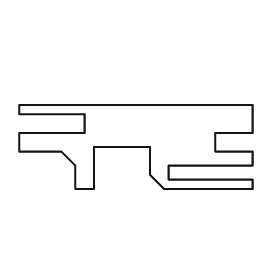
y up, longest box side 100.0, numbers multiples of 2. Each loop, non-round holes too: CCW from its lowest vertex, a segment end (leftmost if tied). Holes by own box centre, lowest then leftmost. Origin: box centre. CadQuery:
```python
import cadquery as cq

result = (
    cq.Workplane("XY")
    .moveTo(-26.0, -18.0)
    .lineTo(-18.0, -18.0)
    .lineTo(-18.0, 0.0)
    .lineTo(6.0, 0.0)
    .lineTo(6.0, -12.0)
    .lineTo(12.0, -18.0)
    .lineTo(50.0, -18.0)
    .lineTo(50.0, -14.0)
    .lineTo(14.0, -14.0)
    .lineTo(14.0, -8.0)
    .lineTo(50.0, -8.0)
    .lineTo(50.0, -2.0)
    .lineTo(34.0, -2.0)
    .lineTo(34.0, 6.0)
    .lineTo(50.0, 6.0)
    .lineTo(50.0, 18.0)
    .lineTo(-50.0, 18.0)
    .lineTo(-50.0, 14.0)
    .lineTo(-22.0, 14.0)
    .lineTo(-22.0, 6.0)
    .lineTo(-50.0, 6.0)
    .lineTo(-50.0, -2.0)
    .lineTo(-32.0, -2.0)
    .lineTo(-26.0, -8.0)
    .close()
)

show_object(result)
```